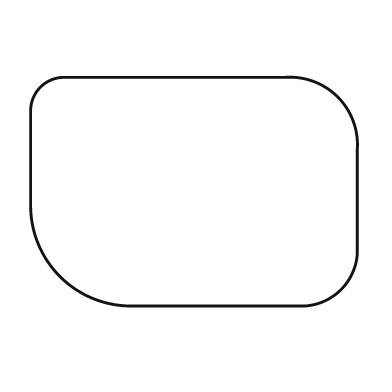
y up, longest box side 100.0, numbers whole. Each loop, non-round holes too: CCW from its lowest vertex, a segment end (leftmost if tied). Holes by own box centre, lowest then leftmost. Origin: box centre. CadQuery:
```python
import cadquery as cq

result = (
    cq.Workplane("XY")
    .moveTo(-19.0, -35.0)
    .lineTo(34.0, -35.0)
    .threePointArc((45.0, -30.0), (50.0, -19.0))
    .lineTo(50.0, 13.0)
    .threePointArc((44.0, 29.0), (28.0, 35.0))
    .lineTo(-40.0, 35.0)
    .threePointArc((-47.0, 32.0), (-50.0, 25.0))
    .lineTo(-50.0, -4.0)
    .threePointArc((-41.0, -26.0), (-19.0, -35.0))
    .close()
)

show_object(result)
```